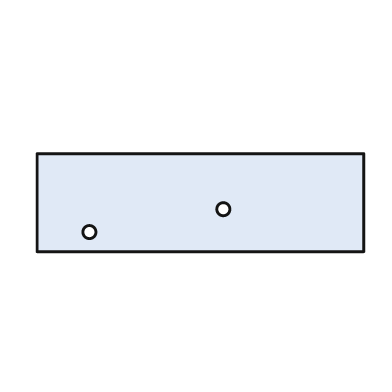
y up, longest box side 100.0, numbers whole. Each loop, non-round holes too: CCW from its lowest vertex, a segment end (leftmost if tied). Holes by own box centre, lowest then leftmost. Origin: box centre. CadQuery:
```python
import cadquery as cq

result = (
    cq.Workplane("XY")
    .moveTo(-50.0, -15.0)
    .lineTo(50.0, -15.0)
    .lineTo(50.0, 15.0)
    .lineTo(-50.0, 15.0)
    .close()
    .moveTo(-34.0, -9.0)
    .circle(2.0)
    .moveTo(7.0, -2.0)
    .circle(2.0)
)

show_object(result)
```